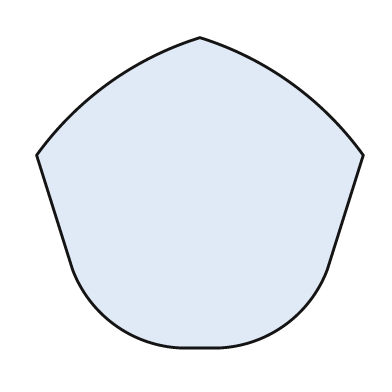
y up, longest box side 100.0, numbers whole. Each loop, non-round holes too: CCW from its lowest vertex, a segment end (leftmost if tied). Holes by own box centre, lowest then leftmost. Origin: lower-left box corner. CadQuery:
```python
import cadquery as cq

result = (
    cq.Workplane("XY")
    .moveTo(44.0, 0.0)
    .lineTo(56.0, 0.0)
    .threePointArc((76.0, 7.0), (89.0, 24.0))
    .lineTo(100.0, 59.0)
    .threePointArc((78.0, 81.0), (50.0, 95.0))
    .threePointArc((22.0, 81.0), (0.0, 59.0))
    .lineTo(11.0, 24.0)
    .threePointArc((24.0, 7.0), (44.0, 0.0))
    .close()
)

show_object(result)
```